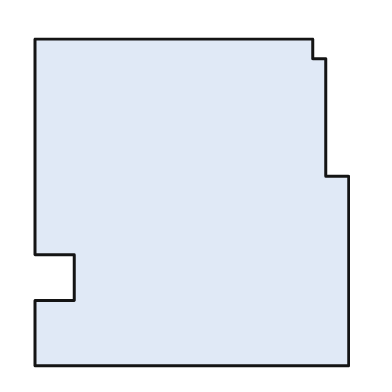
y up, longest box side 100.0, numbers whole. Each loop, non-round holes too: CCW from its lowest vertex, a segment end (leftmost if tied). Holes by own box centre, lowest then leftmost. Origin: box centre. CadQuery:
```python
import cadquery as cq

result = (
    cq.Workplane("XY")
    .moveTo(-48.0, -50.0)
    .lineTo(48.0, -50.0)
    .lineTo(48.0, 8.0)
    .lineTo(41.0, 8.0)
    .lineTo(41.0, 44.0)
    .lineTo(37.0, 44.0)
    .lineTo(37.0, 50.0)
    .lineTo(-48.0, 50.0)
    .lineTo(-48.0, -16.0)
    .lineTo(-36.0, -16.0)
    .lineTo(-36.0, -30.0)
    .lineTo(-48.0, -30.0)
    .close()
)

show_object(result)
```